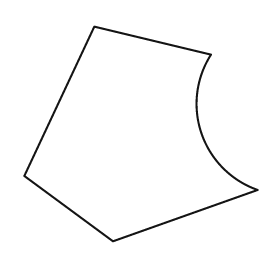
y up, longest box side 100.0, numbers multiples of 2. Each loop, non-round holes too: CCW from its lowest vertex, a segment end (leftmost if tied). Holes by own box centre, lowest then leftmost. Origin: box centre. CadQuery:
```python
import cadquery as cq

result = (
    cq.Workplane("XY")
    .moveTo(-12.0, -46.0)
    .lineTo(50.0, -24.0)
    .threePointArc((26.0, 0.0), (30.0, 34.0))
    .lineTo(-20.0, 46.0)
    .lineTo(-50.0, -18.0)
    .close()
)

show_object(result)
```